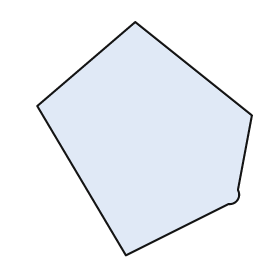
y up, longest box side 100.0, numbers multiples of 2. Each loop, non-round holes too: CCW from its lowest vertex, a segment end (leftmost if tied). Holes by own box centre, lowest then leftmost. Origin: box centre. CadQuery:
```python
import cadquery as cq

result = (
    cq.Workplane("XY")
    .moveTo(-8.0, -50.0)
    .lineTo(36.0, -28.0)
    .threePointArc((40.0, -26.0), (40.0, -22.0))
    .lineTo(46.0, 10.0)
    .lineTo(-4.0, 50.0)
    .lineTo(-46.0, 14.0)
    .close()
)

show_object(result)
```